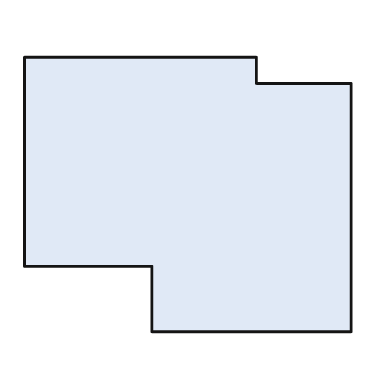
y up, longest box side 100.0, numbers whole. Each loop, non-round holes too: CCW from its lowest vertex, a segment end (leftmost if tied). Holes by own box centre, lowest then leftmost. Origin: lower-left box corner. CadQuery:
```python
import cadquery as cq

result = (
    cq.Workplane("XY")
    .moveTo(39.0, 0.0)
    .lineTo(100.0, 0.0)
    .lineTo(100.0, 76.0)
    .lineTo(71.0, 76.0)
    .lineTo(71.0, 84.0)
    .lineTo(0.0, 84.0)
    .lineTo(0.0, 20.0)
    .lineTo(39.0, 20.0)
    .close()
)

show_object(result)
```